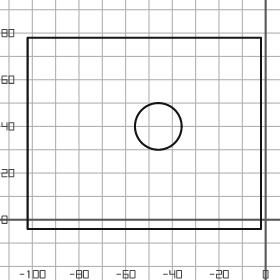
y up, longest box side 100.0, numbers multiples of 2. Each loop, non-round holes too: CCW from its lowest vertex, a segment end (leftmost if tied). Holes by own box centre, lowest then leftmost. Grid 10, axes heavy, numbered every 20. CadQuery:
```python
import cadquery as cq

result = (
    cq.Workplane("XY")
    .moveTo(-102.0, -4.0)
    .lineTo(-2.0, -4.0)
    .lineTo(-2.0, 78.0)
    .lineTo(-102.0, 78.0)
    .close()
    .moveTo(-46.0, 40.0)
    .circle(10.0)
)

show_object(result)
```